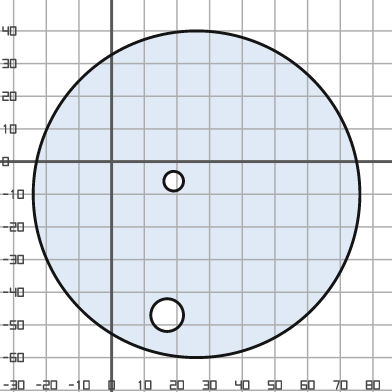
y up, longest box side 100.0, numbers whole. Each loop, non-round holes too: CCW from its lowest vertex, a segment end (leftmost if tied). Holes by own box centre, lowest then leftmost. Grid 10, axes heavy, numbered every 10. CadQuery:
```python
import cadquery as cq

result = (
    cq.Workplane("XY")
    .moveTo(26.0, -10.0)
    .circle(50.0)
    .moveTo(17.0, -47.0)
    .circle(5.0)
    .moveTo(19.0, -6.0)
    .circle(3.0)
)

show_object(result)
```